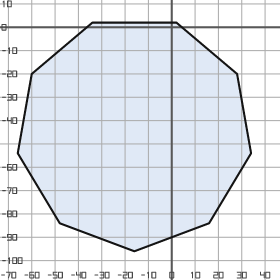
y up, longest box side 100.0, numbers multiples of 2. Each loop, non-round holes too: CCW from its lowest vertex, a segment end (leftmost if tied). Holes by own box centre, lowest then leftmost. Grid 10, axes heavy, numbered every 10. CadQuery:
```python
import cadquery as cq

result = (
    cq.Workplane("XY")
    .moveTo(-16.0, -96.0)
    .lineTo(16.0, -84.0)
    .lineTo(34.0, -54.0)
    .lineTo(28.0, -20.0)
    .lineTo(2.0, 2.0)
    .lineTo(-34.0, 2.0)
    .lineTo(-60.0, -20.0)
    .lineTo(-66.0, -54.0)
    .lineTo(-48.0, -84.0)
    .close()
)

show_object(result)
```